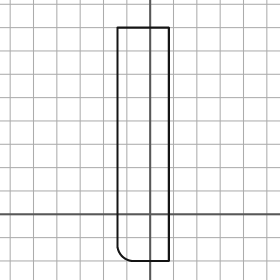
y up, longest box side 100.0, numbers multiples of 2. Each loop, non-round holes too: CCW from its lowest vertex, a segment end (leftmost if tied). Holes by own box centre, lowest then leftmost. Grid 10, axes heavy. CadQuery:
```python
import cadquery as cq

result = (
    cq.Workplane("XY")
    .moveTo(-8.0, -20.0)
    .lineTo(8.0, -20.0)
    .lineTo(8.0, 80.0)
    .lineTo(-14.0, 80.0)
    .lineTo(-14.0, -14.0)
    .threePointArc((-12.0, -18.0), (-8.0, -20.0))
    .close()
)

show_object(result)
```